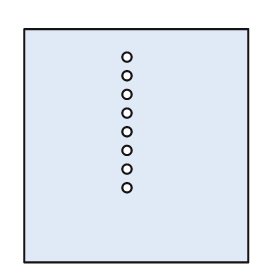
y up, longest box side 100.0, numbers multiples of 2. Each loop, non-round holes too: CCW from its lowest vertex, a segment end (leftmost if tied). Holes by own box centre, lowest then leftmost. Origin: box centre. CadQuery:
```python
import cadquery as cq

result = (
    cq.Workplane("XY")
    .moveTo(-48.0, -50.0)
    .lineTo(48.0, -50.0)
    .lineTo(48.0, 50.0)
    .lineTo(-48.0, 50.0)
    .close()
    .moveTo(-4.0, -18.0)
    .circle(2.0)
    .moveTo(-4.0, -10.0)
    .circle(2.0)
    .moveTo(-4.0, -2.0)
    .circle(2.0)
    .moveTo(-4.0, 6.0)
    .circle(2.0)
    .moveTo(-4.0, 14.0)
    .circle(2.0)
    .moveTo(-4.0, 22.0)
    .circle(2.0)
    .moveTo(-4.0, 30.0)
    .circle(2.0)
    .moveTo(-4.0, 38.0)
    .circle(2.0)
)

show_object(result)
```